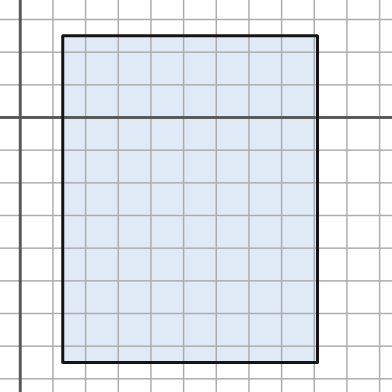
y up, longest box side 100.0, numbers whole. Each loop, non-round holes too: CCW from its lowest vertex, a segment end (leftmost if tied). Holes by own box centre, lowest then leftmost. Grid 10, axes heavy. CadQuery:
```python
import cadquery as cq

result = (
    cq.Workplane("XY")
    .moveTo(13.0, -75.0)
    .lineTo(91.0, -75.0)
    .lineTo(91.0, 25.0)
    .lineTo(13.0, 25.0)
    .close()
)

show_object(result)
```